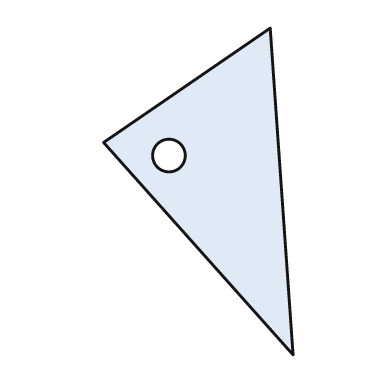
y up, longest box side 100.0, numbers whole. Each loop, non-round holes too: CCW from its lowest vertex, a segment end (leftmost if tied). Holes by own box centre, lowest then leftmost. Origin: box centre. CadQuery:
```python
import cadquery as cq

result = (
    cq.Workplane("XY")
    .moveTo(29.0, -50.0)
    .lineTo(22.0, 50.0)
    .lineTo(-29.0, 15.0)
    .close()
    .moveTo(-9.0, 11.0)
    .circle(5.0)
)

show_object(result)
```